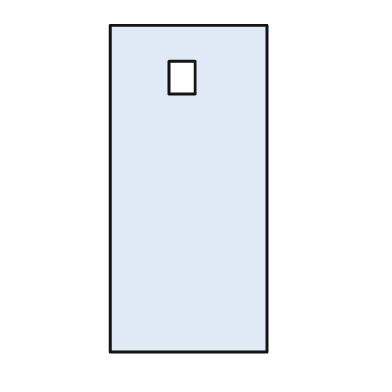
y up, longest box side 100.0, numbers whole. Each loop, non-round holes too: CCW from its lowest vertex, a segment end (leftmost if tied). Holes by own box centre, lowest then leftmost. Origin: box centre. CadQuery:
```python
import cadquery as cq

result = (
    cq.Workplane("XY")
    .moveTo(-24.0, -50.0)
    .lineTo(24.0, -50.0)
    .lineTo(24.0, 50.0)
    .lineTo(-24.0, 50.0)
    .close()
    .moveTo(-6.0, 29.0)
    .lineTo(2.0, 29.0)
    .lineTo(2.0, 39.0)
    .lineTo(-6.0, 39.0)
    .close()
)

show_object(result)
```